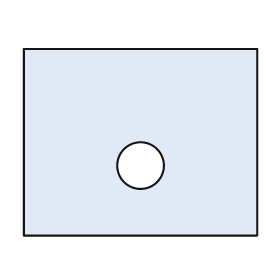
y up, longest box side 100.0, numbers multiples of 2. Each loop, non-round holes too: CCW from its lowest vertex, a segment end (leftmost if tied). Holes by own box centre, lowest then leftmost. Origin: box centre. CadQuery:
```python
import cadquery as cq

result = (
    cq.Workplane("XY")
    .moveTo(-50.0, -40.0)
    .lineTo(50.0, -40.0)
    .lineTo(50.0, 40.0)
    .lineTo(-50.0, 40.0)
    .close()
    .moveTo(0.0, -10.0)
    .circle(10.0)
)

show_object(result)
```